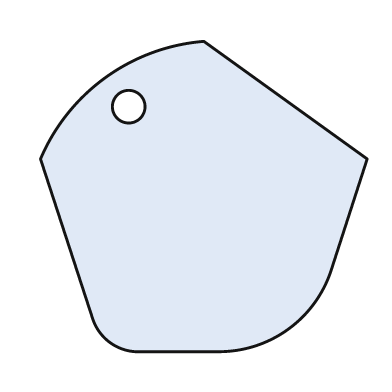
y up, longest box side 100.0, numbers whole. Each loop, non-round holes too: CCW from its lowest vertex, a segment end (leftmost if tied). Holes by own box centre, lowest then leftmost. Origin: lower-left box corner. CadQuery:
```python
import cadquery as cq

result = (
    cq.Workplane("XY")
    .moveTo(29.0, 0.0)
    .lineTo(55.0, 0.0)
    .threePointArc((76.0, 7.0), (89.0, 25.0))
    .lineTo(100.0, 59.0)
    .lineTo(50.0, 95.0)
    .threePointArc((20.0, 84.0), (0.0, 59.0))
    .lineTo(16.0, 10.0)
    .threePointArc((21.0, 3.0), (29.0, 0.0))
    .close()
    .moveTo(27.0, 75.0)
    .circle(5.0)
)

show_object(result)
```